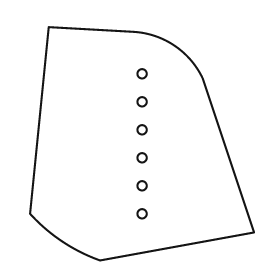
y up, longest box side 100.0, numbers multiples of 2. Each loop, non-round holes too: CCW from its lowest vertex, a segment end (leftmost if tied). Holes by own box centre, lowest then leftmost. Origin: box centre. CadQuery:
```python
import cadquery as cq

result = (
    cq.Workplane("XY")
    .moveTo(-18.0, -50.0)
    .lineTo(48.0, -38.0)
    .lineTo(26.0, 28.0)
    .threePointArc((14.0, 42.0), (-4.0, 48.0))
    .lineTo(-40.0, 50.0)
    .lineTo(-48.0, -30.0)
    .threePointArc((-34.0, -42.0), (-18.0, -50.0))
    .close()
    .moveTo(0.0, -30.0)
    .circle(2.0)
    .moveTo(0.0, -18.0)
    .circle(2.0)
    .moveTo(0.0, -6.0)
    .circle(2.0)
    .moveTo(0.0, 6.0)
    .circle(2.0)
    .moveTo(0.0, 18.0)
    .circle(2.0)
    .moveTo(0.0, 30.0)
    .circle(2.0)
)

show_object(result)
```